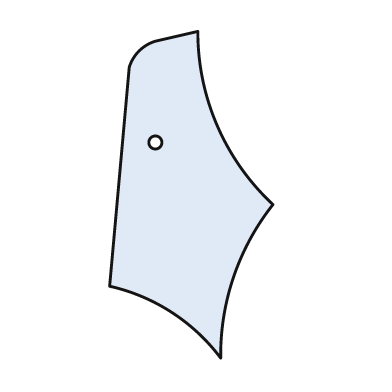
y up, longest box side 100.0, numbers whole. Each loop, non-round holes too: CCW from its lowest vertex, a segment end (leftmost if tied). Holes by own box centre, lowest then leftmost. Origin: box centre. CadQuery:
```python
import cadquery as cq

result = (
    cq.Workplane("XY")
    .moveTo(9.0, -50.0)
    .threePointArc((13.0, -25.0), (25.0, -3.0))
    .threePointArc((8.0, 21.0), (2.0, 50.0))
    .lineTo(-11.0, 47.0)
    .threePointArc((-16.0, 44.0), (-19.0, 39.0))
    .lineTo(-25.0, -28.0)
    .threePointArc((-6.0, -36.0), (9.0, -50.0))
    .close()
    .moveTo(-11.0, 16.0)
    .circle(2.0)
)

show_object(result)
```